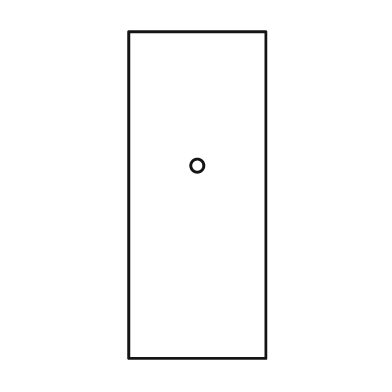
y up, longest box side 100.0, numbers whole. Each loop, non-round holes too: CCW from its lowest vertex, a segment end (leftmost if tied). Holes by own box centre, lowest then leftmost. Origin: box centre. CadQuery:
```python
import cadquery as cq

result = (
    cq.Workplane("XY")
    .moveTo(-21.0, -50.0)
    .lineTo(21.0, -50.0)
    .lineTo(21.0, 50.0)
    .lineTo(-21.0, 50.0)
    .close()
    .moveTo(0.0, 9.0)
    .circle(2.0)
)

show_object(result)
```